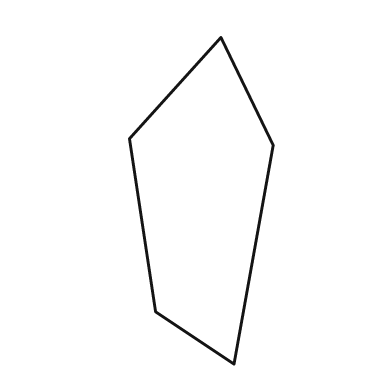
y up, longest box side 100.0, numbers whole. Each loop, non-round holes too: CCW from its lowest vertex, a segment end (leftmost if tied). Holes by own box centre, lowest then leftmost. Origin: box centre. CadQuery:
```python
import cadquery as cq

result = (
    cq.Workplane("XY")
    .moveTo(10.0, -50.0)
    .lineTo(22.0, 17.0)
    .lineTo(6.0, 50.0)
    .lineTo(-22.0, 19.0)
    .lineTo(-14.0, -34.0)
    .close()
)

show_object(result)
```